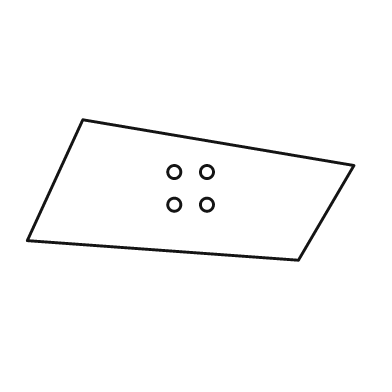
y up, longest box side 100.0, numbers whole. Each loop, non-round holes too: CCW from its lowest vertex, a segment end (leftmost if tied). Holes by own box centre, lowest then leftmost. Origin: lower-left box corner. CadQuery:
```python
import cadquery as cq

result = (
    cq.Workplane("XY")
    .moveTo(83.0, 0.0)
    .lineTo(100.0, 29.0)
    .lineTo(17.0, 43.0)
    .lineTo(0.0, 6.0)
    .close()
    .moveTo(45.0, 17.0)
    .circle(2.0)
    .moveTo(55.0, 17.0)
    .circle(2.0)
    .moveTo(45.0, 27.0)
    .circle(2.0)
    .moveTo(55.0, 27.0)
    .circle(2.0)
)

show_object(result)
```